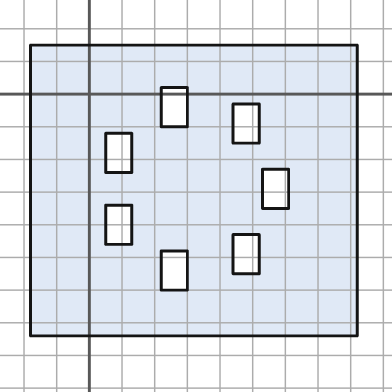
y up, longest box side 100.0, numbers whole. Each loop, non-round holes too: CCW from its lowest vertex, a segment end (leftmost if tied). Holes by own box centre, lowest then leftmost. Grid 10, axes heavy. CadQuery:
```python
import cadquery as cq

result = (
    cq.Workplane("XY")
    .moveTo(-18.0, -74.0)
    .lineTo(82.0, -74.0)
    .lineTo(82.0, 15.0)
    .lineTo(-18.0, 15.0)
    .close()
    .moveTo(22.0, -60.0)
    .lineTo(30.0, -60.0)
    .lineTo(30.0, -48.0)
    .lineTo(22.0, -48.0)
    .close()
    .moveTo(44.0, -55.0)
    .lineTo(52.0, -55.0)
    .lineTo(52.0, -43.0)
    .lineTo(44.0, -43.0)
    .close()
    .moveTo(5.0, -46.0)
    .lineTo(13.0, -46.0)
    .lineTo(13.0, -34.0)
    .lineTo(5.0, -34.0)
    .close()
    .moveTo(53.0, -35.0)
    .lineTo(61.0, -35.0)
    .lineTo(61.0, -23.0)
    .lineTo(53.0, -23.0)
    .close()
    .moveTo(5.0, -24.0)
    .lineTo(13.0, -24.0)
    .lineTo(13.0, -12.0)
    .lineTo(5.0, -12.0)
    .close()
    .moveTo(44.0, -15.0)
    .lineTo(52.0, -15.0)
    .lineTo(52.0, -3.0)
    .lineTo(44.0, -3.0)
    .close()
    .moveTo(22.0, -10.0)
    .lineTo(30.0, -10.0)
    .lineTo(30.0, 2.0)
    .lineTo(22.0, 2.0)
    .close()
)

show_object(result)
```